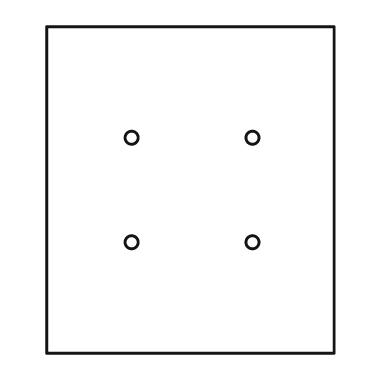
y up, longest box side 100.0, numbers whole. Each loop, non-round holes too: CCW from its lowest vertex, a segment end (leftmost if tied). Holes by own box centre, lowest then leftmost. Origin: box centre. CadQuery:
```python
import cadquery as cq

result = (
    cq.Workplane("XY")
    .moveTo(-44.0, -50.0)
    .lineTo(44.0, -50.0)
    .lineTo(44.0, 50.0)
    .lineTo(-44.0, 50.0)
    .close()
    .moveTo(-18.0, -16.0)
    .circle(2.0)
    .moveTo(19.0, -16.0)
    .circle(2.0)
    .moveTo(-18.0, 16.0)
    .circle(2.0)
    .moveTo(19.0, 16.0)
    .circle(2.0)
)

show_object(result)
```